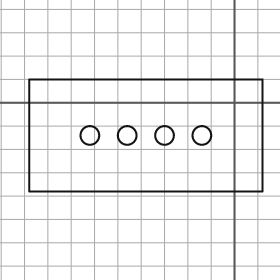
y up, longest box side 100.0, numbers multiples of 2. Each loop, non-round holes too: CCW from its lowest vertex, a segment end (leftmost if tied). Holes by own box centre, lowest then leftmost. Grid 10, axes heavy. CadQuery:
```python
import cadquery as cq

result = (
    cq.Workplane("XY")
    .moveTo(-88.0, -38.0)
    .lineTo(12.0, -38.0)
    .lineTo(12.0, 10.0)
    .lineTo(-88.0, 10.0)
    .close()
    .moveTo(-62.0, -14.0)
    .circle(4.0)
    .moveTo(-46.0, -14.0)
    .circle(4.0)
    .moveTo(-30.0, -14.0)
    .circle(4.0)
    .moveTo(-14.0, -14.0)
    .circle(4.0)
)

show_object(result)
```